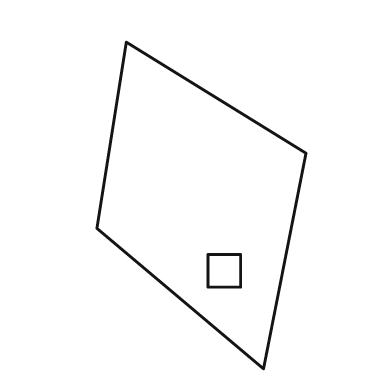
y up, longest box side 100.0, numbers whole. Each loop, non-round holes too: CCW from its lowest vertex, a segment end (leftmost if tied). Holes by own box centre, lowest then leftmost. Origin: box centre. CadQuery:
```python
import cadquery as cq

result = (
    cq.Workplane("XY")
    .moveTo(19.0, -50.0)
    .lineTo(32.0, 16.0)
    .lineTo(-23.0, 50.0)
    .lineTo(-32.0, -7.0)
    .close()
    .moveTo(2.0, -25.0)
    .lineTo(12.0, -25.0)
    .lineTo(12.0, -15.0)
    .lineTo(2.0, -15.0)
    .close()
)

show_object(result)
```